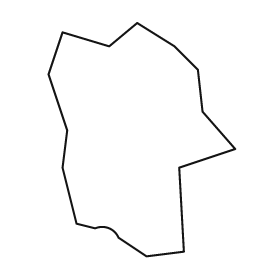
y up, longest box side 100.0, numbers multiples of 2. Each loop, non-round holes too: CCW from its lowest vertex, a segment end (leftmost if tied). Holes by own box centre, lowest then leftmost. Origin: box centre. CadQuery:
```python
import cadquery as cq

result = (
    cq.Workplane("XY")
    .moveTo(2.0, -50.0)
    .lineTo(18.0, -48.0)
    .lineTo(16.0, -12.0)
    .lineTo(40.0, -4.0)
    .lineTo(26.0, 12.0)
    .lineTo(24.0, 30.0)
    .lineTo(14.0, 40.0)
    .lineTo(-2.0, 50.0)
    .lineTo(-14.0, 40.0)
    .lineTo(-34.0, 46.0)
    .lineTo(-40.0, 28.0)
    .lineTo(-32.0, 4.0)
    .lineTo(-34.0, -12.0)
    .lineTo(-28.0, -36.0)
    .lineTo(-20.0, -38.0)
    .threePointArc((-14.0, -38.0), (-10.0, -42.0))
    .close()
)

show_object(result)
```